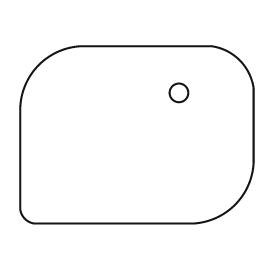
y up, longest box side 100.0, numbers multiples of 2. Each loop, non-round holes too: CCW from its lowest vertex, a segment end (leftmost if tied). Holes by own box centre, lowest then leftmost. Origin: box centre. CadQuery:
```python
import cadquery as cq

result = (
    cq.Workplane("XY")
    .moveTo(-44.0, -38.0)
    .lineTo(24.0, -38.0)
    .threePointArc((42.0, -30.0), (50.0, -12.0))
    .lineTo(50.0, 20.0)
    .threePointArc((44.0, 32.0), (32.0, 38.0))
    .lineTo(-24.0, 38.0)
    .threePointArc((-42.0, 30.0), (-50.0, 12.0))
    .lineTo(-50.0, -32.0)
    .threePointArc((-48.0, -36.0), (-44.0, -38.0))
    .close()
    .moveTo(18.0, 18.0)
    .circle(4.0)
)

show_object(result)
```